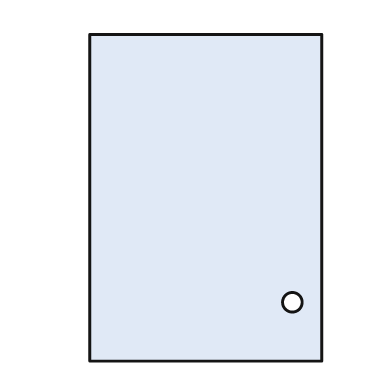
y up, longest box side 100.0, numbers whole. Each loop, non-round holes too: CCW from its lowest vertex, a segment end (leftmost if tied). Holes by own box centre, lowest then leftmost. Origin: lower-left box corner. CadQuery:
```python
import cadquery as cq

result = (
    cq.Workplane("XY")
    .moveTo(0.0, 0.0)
    .lineTo(71.0, 0.0)
    .lineTo(71.0, 100.0)
    .lineTo(0.0, 100.0)
    .close()
    .moveTo(62.0, 18.0)
    .circle(3.0)
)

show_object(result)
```